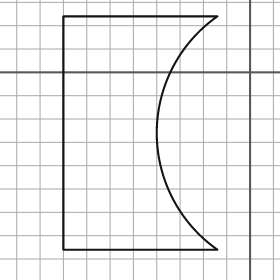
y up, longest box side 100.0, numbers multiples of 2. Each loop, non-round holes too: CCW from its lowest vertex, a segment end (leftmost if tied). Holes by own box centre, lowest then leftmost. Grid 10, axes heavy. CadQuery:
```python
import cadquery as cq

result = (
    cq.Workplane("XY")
    .moveTo(-80.0, -76.0)
    .lineTo(-14.0, -76.0)
    .threePointArc((-40.0, -26.0), (-14.0, 24.0))
    .lineTo(-80.0, 24.0)
    .close()
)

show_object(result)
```